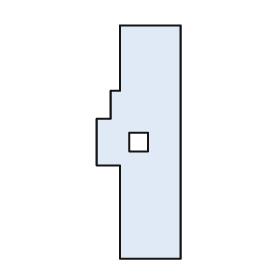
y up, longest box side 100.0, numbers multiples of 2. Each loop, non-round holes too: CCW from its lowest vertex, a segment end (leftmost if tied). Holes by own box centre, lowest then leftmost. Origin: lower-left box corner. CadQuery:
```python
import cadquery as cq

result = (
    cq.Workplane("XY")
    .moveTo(10.0, 0.0)
    .lineTo(36.0, 0.0)
    .lineTo(36.0, 100.0)
    .lineTo(10.0, 100.0)
    .lineTo(10.0, 72.0)
    .lineTo(6.0, 72.0)
    .lineTo(6.0, 60.0)
    .lineTo(0.0, 60.0)
    .lineTo(0.0, 40.0)
    .lineTo(10.0, 40.0)
    .close()
    .moveTo(14.0, 46.0)
    .lineTo(22.0, 46.0)
    .lineTo(22.0, 54.0)
    .lineTo(14.0, 54.0)
    .close()
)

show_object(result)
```